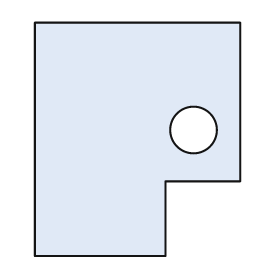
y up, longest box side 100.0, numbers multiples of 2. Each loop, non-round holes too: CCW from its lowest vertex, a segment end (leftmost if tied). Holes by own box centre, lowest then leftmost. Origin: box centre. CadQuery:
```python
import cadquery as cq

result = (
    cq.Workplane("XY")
    .moveTo(-44.0, -50.0)
    .lineTo(12.0, -50.0)
    .lineTo(12.0, -18.0)
    .lineTo(44.0, -18.0)
    .lineTo(44.0, 50.0)
    .lineTo(-44.0, 50.0)
    .close()
    .moveTo(24.0, 4.0)
    .circle(10.0)
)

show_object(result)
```